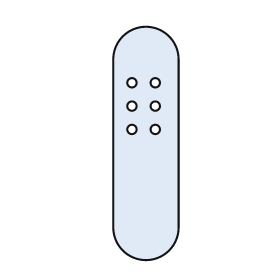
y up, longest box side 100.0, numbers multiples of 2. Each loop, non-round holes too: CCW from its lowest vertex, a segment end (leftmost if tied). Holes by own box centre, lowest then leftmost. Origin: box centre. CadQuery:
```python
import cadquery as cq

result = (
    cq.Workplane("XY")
    .moveTo(-14.0, -36.0)
    .threePointArc((0.0, -50.0), (14.0, -36.0))
    .lineTo(14.0, 36.0)
    .threePointArc((0.0, 50.0), (-14.0, 36.0))
    .close()
    .moveTo(-6.0, 6.0)
    .circle(2.0)
    .moveTo(4.0, 6.0)
    .circle(2.0)
    .moveTo(-6.0, 16.0)
    .circle(2.0)
    .moveTo(4.0, 16.0)
    .circle(2.0)
    .moveTo(-6.0, 26.0)
    .circle(2.0)
    .moveTo(4.0, 26.0)
    .circle(2.0)
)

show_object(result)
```